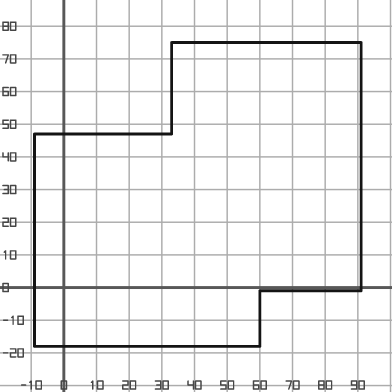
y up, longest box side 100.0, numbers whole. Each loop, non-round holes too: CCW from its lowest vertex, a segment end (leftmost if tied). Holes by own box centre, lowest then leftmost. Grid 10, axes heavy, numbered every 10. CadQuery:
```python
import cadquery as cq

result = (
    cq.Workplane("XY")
    .moveTo(-9.0, -18.0)
    .lineTo(60.0, -18.0)
    .lineTo(60.0, -1.0)
    .lineTo(91.0, -1.0)
    .lineTo(91.0, 75.0)
    .lineTo(33.0, 75.0)
    .lineTo(33.0, 47.0)
    .lineTo(-9.0, 47.0)
    .close()
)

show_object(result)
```